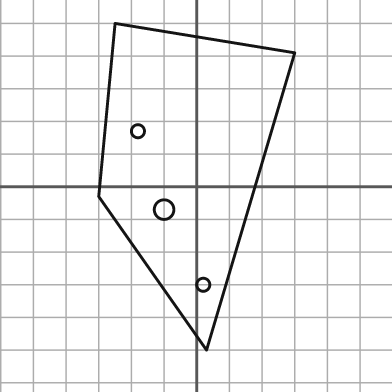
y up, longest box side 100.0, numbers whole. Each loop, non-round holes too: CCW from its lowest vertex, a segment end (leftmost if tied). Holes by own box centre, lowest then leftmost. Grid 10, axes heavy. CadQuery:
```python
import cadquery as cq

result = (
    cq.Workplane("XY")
    .moveTo(3.0, -50.0)
    .lineTo(30.0, 41.0)
    .lineTo(-25.0, 50.0)
    .lineTo(-30.0, -3.0)
    .close()
    .moveTo(2.0, -30.0)
    .circle(2.0)
    .moveTo(-10.0, -7.0)
    .circle(3.0)
    .moveTo(-18.0, 17.0)
    .circle(2.0)
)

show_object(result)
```